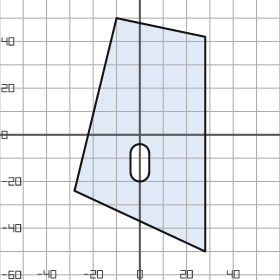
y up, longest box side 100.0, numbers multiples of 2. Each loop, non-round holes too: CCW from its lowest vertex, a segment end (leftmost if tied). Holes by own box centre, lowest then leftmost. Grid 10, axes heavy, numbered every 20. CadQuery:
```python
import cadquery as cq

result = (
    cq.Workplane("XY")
    .moveTo(28.0, -50.0)
    .lineTo(28.0, 42.0)
    .lineTo(-10.0, 50.0)
    .lineTo(-28.0, -24.0)
    .close()
    .moveTo(-4.0, -16.0)
    .threePointArc((0.0, -20.0), (4.0, -16.0))
    .lineTo(4.0, -8.0)
    .threePointArc((0.0, -4.0), (-4.0, -8.0))
    .close()
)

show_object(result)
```